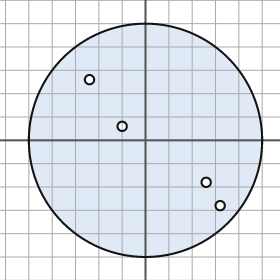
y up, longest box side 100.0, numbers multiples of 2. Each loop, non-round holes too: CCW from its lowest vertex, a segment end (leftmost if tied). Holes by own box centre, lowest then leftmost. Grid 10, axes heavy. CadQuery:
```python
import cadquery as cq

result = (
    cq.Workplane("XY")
    .moveTo(0.0, 0.0)
    .circle(50.0)
    .moveTo(32.0, -28.0)
    .circle(2.0)
    .moveTo(26.0, -18.0)
    .circle(2.0)
    .moveTo(-10.0, 6.0)
    .circle(2.0)
    .moveTo(-24.0, 26.0)
    .circle(2.0)
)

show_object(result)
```